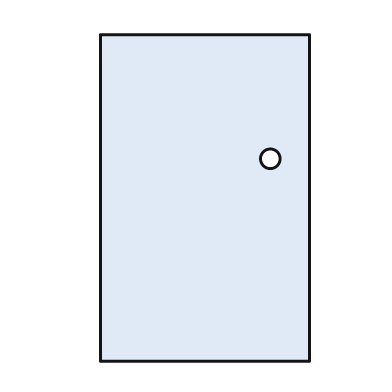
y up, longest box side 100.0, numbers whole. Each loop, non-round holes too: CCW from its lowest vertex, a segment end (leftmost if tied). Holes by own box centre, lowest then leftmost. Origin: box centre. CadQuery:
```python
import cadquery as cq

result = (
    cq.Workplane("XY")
    .moveTo(-32.0, -50.0)
    .lineTo(32.0, -50.0)
    .lineTo(32.0, 50.0)
    .lineTo(-32.0, 50.0)
    .close()
    .moveTo(20.0, 12.0)
    .circle(3.0)
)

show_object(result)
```